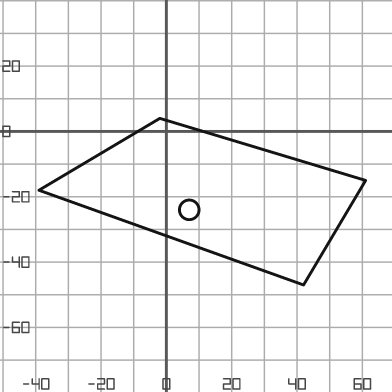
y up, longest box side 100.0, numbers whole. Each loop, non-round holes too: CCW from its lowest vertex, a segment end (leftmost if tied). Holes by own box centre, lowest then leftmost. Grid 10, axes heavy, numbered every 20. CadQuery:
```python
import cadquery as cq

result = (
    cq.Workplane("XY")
    .moveTo(42.0, -47.0)
    .lineTo(61.0, -15.0)
    .lineTo(-2.0, 4.0)
    .lineTo(-39.0, -18.0)
    .close()
    .moveTo(7.0, -24.0)
    .circle(3.0)
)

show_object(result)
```